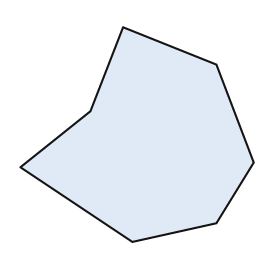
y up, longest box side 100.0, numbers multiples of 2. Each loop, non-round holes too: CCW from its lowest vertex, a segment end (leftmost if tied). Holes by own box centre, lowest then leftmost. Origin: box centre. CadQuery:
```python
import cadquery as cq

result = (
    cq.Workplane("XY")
    .moveTo(-2.0, -46.0)
    .lineTo(34.0, -38.0)
    .lineTo(50.0, -12.0)
    .lineTo(34.0, 30.0)
    .lineTo(-6.0, 46.0)
    .lineTo(-20.0, 10.0)
    .lineTo(-50.0, -14.0)
    .close()
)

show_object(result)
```